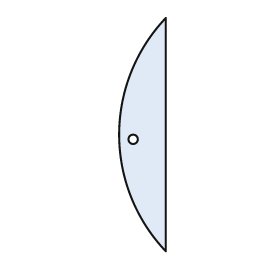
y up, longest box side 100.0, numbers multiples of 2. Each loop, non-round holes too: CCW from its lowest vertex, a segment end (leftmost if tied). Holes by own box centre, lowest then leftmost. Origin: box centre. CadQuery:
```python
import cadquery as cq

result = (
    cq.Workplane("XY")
    .moveTo(10.0, -50.0)
    .lineTo(10.0, 50.0)
    .threePointArc((-10.0, 0.0), (10.0, -50.0))
    .close()
    .moveTo(-4.0, -2.0)
    .circle(2.0)
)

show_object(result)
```